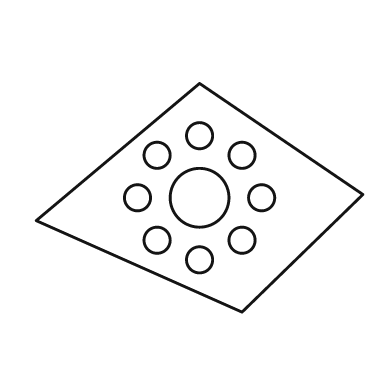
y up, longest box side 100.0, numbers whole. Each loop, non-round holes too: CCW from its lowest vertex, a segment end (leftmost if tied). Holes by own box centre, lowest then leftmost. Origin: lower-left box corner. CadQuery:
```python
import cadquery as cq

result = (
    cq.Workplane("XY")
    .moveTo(63.0, 0.0)
    .lineTo(100.0, 36.0)
    .lineTo(50.0, 70.0)
    .lineTo(0.0, 28.0)
    .close()
    .moveTo(50.0, 16.0)
    .circle(4.0)
    .moveTo(37.0, 22.0)
    .circle(4.0)
    .moveTo(63.0, 22.0)
    .circle(4.0)
    .moveTo(31.0, 35.0)
    .circle(4.0)
    .moveTo(50.0, 35.0)
    .circle(9.0)
    .moveTo(69.0, 35.0)
    .circle(4.0)
    .moveTo(37.0, 48.0)
    .circle(4.0)
    .moveTo(63.0, 48.0)
    .circle(4.0)
    .moveTo(50.0, 54.0)
    .circle(4.0)
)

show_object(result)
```